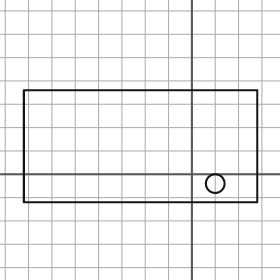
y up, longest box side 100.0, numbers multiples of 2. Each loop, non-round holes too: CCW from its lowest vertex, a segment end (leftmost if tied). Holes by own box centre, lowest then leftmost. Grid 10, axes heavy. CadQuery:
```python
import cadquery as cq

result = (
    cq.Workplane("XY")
    .moveTo(-72.0, -12.0)
    .lineTo(28.0, -12.0)
    .lineTo(28.0, 36.0)
    .lineTo(-72.0, 36.0)
    .close()
    .moveTo(10.0, -4.0)
    .circle(4.0)
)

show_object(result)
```